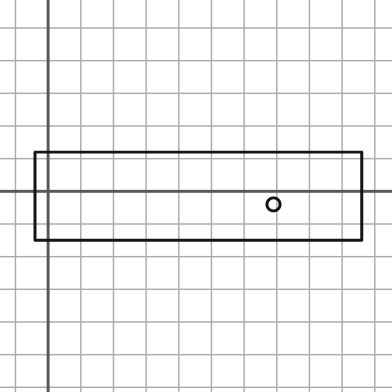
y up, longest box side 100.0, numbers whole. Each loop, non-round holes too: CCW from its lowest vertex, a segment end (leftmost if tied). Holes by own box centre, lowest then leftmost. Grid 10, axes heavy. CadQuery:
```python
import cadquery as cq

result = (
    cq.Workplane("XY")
    .moveTo(-4.0, -15.0)
    .lineTo(96.0, -15.0)
    .lineTo(96.0, 12.0)
    .lineTo(-4.0, 12.0)
    .close()
    .moveTo(69.0, -4.0)
    .circle(2.0)
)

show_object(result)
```